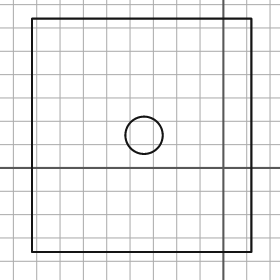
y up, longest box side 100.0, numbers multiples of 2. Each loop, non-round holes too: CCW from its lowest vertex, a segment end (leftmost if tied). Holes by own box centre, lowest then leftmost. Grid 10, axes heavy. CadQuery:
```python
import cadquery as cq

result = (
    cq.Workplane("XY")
    .moveTo(-82.0, -36.0)
    .lineTo(12.0, -36.0)
    .lineTo(12.0, 64.0)
    .lineTo(-82.0, 64.0)
    .close()
    .moveTo(-34.0, 14.0)
    .circle(8.0)
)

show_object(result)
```